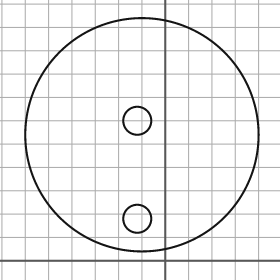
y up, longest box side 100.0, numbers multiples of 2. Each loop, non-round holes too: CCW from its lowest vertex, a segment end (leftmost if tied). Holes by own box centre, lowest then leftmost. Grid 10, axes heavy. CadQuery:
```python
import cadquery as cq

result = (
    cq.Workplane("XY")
    .moveTo(-10.0, 54.0)
    .circle(50.0)
    .moveTo(-12.0, 18.0)
    .circle(6.0)
    .moveTo(-12.0, 60.0)
    .circle(6.0)
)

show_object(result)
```